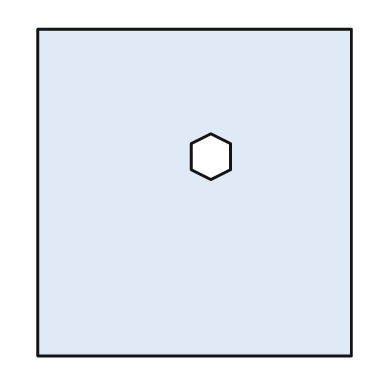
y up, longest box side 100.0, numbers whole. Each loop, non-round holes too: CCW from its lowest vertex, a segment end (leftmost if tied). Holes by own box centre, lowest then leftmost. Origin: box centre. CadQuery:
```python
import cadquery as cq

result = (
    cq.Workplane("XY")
    .moveTo(-48.0, -50.0)
    .lineTo(48.0, -50.0)
    .lineTo(48.0, 50.0)
    .lineTo(-48.0, 50.0)
    .close()
    .moveTo(5.0, 4.0)
    .lineTo(11.0, 7.0)
    .lineTo(11.0, 15.0)
    .lineTo(5.0, 18.0)
    .lineTo(-1.0, 15.0)
    .lineTo(-1.0, 7.0)
    .close()
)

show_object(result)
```